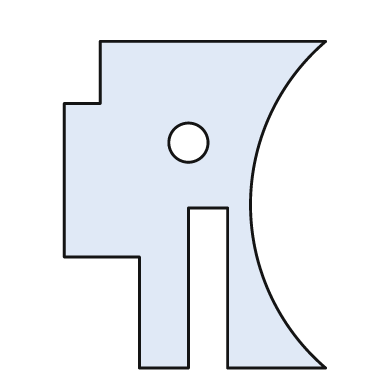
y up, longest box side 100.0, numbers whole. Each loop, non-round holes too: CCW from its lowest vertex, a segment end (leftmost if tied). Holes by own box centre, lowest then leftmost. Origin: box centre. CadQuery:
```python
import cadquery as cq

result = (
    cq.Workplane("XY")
    .moveTo(-17.0, -50.0)
    .lineTo(-2.0, -50.0)
    .lineTo(-2.0, -1.0)
    .lineTo(10.0, -1.0)
    .lineTo(10.0, -50.0)
    .lineTo(40.0, -50.0)
    .threePointArc((17.0, 0.0), (40.0, 50.0))
    .lineTo(-29.0, 50.0)
    .lineTo(-29.0, 31.0)
    .lineTo(-40.0, 31.0)
    .lineTo(-40.0, -16.0)
    .lineTo(-17.0, -16.0)
    .close()
    .moveTo(-2.0, 19.0)
    .circle(6.0)
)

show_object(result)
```